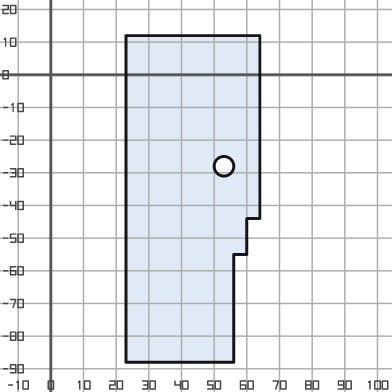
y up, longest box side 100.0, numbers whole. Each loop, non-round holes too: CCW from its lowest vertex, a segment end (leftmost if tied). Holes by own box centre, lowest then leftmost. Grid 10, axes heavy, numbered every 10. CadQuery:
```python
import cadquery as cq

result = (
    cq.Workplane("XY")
    .moveTo(23.0, -88.0)
    .lineTo(56.0, -88.0)
    .lineTo(56.0, -55.0)
    .lineTo(60.0, -55.0)
    .lineTo(60.0, -44.0)
    .lineTo(64.0, -44.0)
    .lineTo(64.0, 12.0)
    .lineTo(23.0, 12.0)
    .close()
    .moveTo(53.0, -28.0)
    .circle(3.0)
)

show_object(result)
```